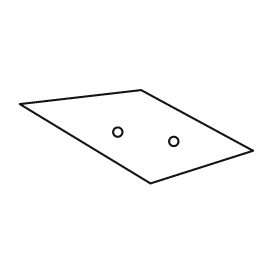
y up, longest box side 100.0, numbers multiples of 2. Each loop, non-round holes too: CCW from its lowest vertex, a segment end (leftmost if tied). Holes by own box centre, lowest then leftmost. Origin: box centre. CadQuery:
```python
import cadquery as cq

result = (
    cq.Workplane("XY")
    .moveTo(6.0, -20.0)
    .lineTo(50.0, -6.0)
    .lineTo(2.0, 20.0)
    .lineTo(-50.0, 14.0)
    .close()
    .moveTo(16.0, -2.0)
    .circle(2.0)
    .moveTo(-8.0, 2.0)
    .circle(2.0)
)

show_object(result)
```